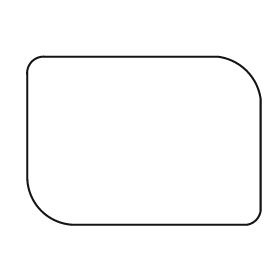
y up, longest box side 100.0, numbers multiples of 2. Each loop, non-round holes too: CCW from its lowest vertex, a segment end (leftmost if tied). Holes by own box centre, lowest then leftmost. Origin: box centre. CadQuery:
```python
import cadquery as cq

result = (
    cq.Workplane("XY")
    .moveTo(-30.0, -36.0)
    .lineTo(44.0, -36.0)
    .threePointArc((48.0, -34.0), (50.0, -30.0))
    .lineTo(50.0, 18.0)
    .threePointArc((44.0, 30.0), (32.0, 36.0))
    .lineTo(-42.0, 36.0)
    .threePointArc((-48.0, 34.0), (-50.0, 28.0))
    .lineTo(-50.0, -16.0)
    .threePointArc((-44.0, -30.0), (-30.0, -36.0))
    .close()
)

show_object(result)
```